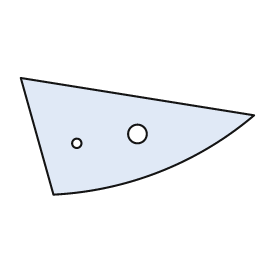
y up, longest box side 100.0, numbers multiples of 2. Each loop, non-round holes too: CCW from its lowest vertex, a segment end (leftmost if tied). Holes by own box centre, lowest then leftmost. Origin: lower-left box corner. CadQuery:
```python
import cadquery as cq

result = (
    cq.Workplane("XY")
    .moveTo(14.0, 0.0)
    .threePointArc((60.0, 10.0), (100.0, 34.0))
    .lineTo(0.0, 50.0)
    .close()
    .moveTo(24.0, 22.0)
    .circle(2.0)
    .moveTo(50.0, 26.0)
    .circle(4.0)
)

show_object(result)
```